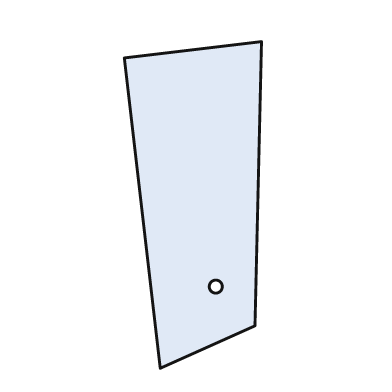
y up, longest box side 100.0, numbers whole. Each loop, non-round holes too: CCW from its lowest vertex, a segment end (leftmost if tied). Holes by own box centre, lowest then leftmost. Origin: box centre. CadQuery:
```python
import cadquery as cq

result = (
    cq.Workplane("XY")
    .moveTo(-10.0, -50.0)
    .lineTo(19.0, -37.0)
    .lineTo(21.0, 50.0)
    .lineTo(-21.0, 45.0)
    .close()
    .moveTo(7.0, -25.0)
    .circle(2.0)
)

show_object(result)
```